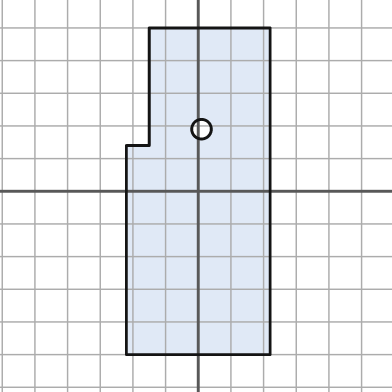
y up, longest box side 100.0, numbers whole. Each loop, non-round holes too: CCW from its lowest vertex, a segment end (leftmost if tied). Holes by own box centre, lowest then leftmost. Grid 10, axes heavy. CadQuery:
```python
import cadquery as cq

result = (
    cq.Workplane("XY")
    .moveTo(-22.0, -50.0)
    .lineTo(22.0, -50.0)
    .lineTo(22.0, 50.0)
    .lineTo(-15.0, 50.0)
    .lineTo(-15.0, 14.0)
    .lineTo(-22.0, 14.0)
    .close()
    .moveTo(1.0, 19.0)
    .circle(3.0)
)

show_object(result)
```